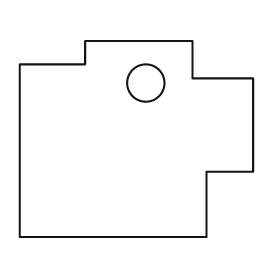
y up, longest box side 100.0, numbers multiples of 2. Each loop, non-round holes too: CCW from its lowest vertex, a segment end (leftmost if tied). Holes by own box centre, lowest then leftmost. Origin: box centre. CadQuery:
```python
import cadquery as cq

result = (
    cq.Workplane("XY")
    .moveTo(-50.0, -42.0)
    .lineTo(30.0, -42.0)
    .lineTo(30.0, -14.0)
    .lineTo(50.0, -14.0)
    .lineTo(50.0, 26.0)
    .lineTo(24.0, 26.0)
    .lineTo(24.0, 42.0)
    .lineTo(-22.0, 42.0)
    .lineTo(-22.0, 32.0)
    .lineTo(-50.0, 32.0)
    .close()
    .moveTo(4.0, 24.0)
    .circle(8.0)
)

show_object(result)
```